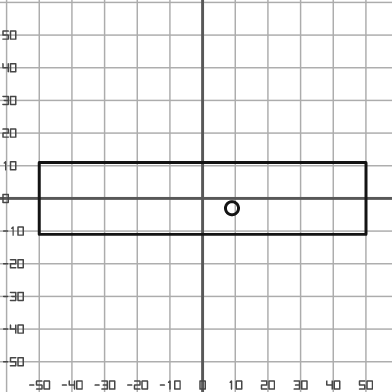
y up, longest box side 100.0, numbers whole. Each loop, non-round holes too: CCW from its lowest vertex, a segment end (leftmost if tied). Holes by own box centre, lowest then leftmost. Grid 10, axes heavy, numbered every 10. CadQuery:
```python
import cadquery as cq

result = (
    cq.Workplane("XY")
    .moveTo(-50.0, -11.0)
    .lineTo(50.0, -11.0)
    .lineTo(50.0, 11.0)
    .lineTo(-50.0, 11.0)
    .close()
    .moveTo(9.0, -3.0)
    .circle(2.0)
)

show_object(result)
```